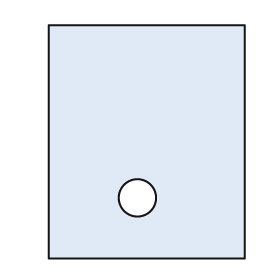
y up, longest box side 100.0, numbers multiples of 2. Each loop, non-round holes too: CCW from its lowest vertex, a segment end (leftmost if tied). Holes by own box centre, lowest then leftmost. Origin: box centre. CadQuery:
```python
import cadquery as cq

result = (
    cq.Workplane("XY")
    .moveTo(-42.0, -50.0)
    .lineTo(42.0, -50.0)
    .lineTo(42.0, 50.0)
    .lineTo(-42.0, 50.0)
    .close()
    .moveTo(-4.0, -24.0)
    .circle(8.0)
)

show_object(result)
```